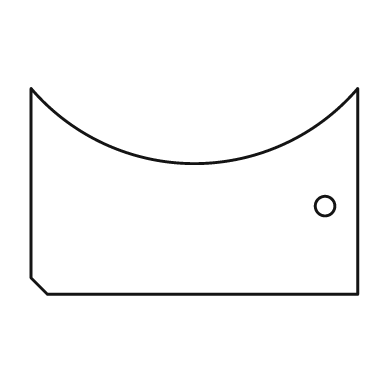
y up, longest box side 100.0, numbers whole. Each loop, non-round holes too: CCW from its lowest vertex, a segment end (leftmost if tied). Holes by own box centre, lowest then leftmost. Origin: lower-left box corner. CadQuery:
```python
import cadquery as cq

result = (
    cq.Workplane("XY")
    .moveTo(5.0, 0.0)
    .lineTo(100.0, 0.0)
    .lineTo(100.0, 63.0)
    .threePointArc((50.0, 40.0), (0.0, 63.0))
    .lineTo(0.0, 5.0)
    .close()
    .moveTo(90.0, 27.0)
    .circle(3.0)
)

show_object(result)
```